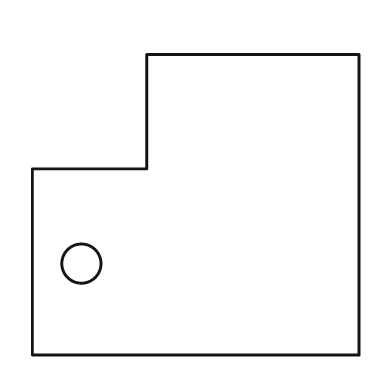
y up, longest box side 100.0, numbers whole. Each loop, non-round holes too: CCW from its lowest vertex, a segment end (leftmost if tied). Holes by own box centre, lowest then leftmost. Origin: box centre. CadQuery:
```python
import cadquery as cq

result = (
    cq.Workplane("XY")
    .moveTo(-50.0, -46.0)
    .lineTo(50.0, -46.0)
    .lineTo(50.0, 46.0)
    .lineTo(-15.0, 46.0)
    .lineTo(-15.0, 11.0)
    .lineTo(-50.0, 11.0)
    .close()
    .moveTo(-35.0, -18.0)
    .circle(6.0)
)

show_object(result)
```